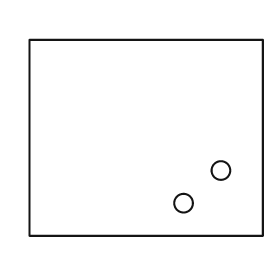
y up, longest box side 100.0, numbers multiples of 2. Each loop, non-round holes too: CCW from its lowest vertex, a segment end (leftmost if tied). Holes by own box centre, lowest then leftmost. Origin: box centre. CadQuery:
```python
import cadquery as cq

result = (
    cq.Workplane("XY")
    .moveTo(-50.0, -42.0)
    .lineTo(50.0, -42.0)
    .lineTo(50.0, 42.0)
    .lineTo(-50.0, 42.0)
    .close()
    .moveTo(16.0, -28.0)
    .circle(4.0)
    .moveTo(32.0, -14.0)
    .circle(4.0)
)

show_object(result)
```